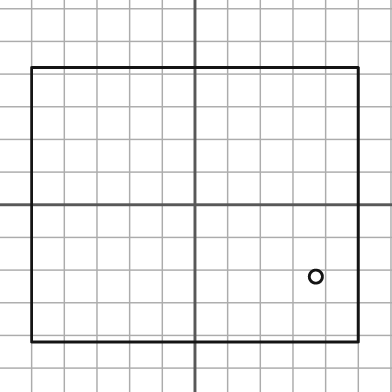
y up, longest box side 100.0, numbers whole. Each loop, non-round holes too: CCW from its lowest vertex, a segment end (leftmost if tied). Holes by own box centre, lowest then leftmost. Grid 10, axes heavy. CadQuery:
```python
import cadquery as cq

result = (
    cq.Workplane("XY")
    .moveTo(-50.0, -42.0)
    .lineTo(50.0, -42.0)
    .lineTo(50.0, 42.0)
    .lineTo(-50.0, 42.0)
    .close()
    .moveTo(37.0, -22.0)
    .circle(2.0)
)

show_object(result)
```